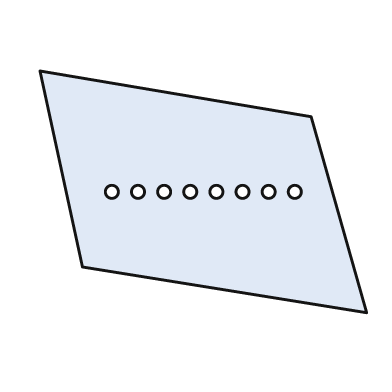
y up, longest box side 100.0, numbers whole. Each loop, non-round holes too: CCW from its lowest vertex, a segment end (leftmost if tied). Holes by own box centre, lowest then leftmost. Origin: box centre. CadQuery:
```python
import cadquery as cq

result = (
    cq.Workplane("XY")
    .moveTo(50.0, -37.0)
    .lineTo(33.0, 23.0)
    .lineTo(-50.0, 37.0)
    .lineTo(-37.0, -23.0)
    .close()
    .moveTo(-28.0, 0.0)
    .circle(2.0)
    .moveTo(-20.0, 0.0)
    .circle(2.0)
    .moveTo(-12.0, 0.0)
    .circle(2.0)
    .moveTo(-4.0, 0.0)
    .circle(2.0)
    .moveTo(4.0, 0.0)
    .circle(2.0)
    .moveTo(12.0, 0.0)
    .circle(2.0)
    .moveTo(20.0, 0.0)
    .circle(2.0)
    .moveTo(28.0, 0.0)
    .circle(2.0)
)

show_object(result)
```